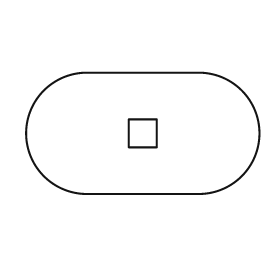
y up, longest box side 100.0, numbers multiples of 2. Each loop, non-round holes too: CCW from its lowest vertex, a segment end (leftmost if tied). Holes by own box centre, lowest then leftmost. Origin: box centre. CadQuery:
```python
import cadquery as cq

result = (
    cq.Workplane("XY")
    .moveTo(-24.0, -26.0)
    .lineTo(24.0, -26.0)
    .threePointArc((50.0, 0.0), (24.0, 26.0))
    .lineTo(-24.0, 26.0)
    .threePointArc((-50.0, 0.0), (-24.0, -26.0))
    .close()
    .moveTo(-6.0, -6.0)
    .lineTo(6.0, -6.0)
    .lineTo(6.0, 6.0)
    .lineTo(-6.0, 6.0)
    .close()
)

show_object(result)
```